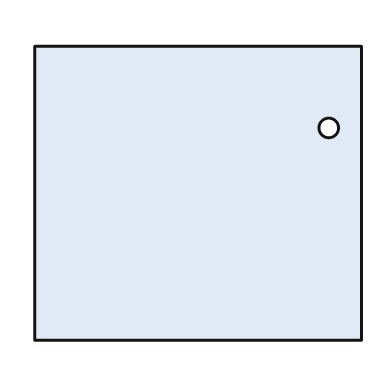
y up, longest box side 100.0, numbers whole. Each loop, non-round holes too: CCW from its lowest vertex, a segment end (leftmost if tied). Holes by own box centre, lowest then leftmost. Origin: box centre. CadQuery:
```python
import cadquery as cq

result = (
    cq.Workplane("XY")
    .moveTo(-50.0, -45.0)
    .lineTo(50.0, -45.0)
    .lineTo(50.0, 45.0)
    .lineTo(-50.0, 45.0)
    .close()
    .moveTo(40.0, 20.0)
    .circle(3.0)
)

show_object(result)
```